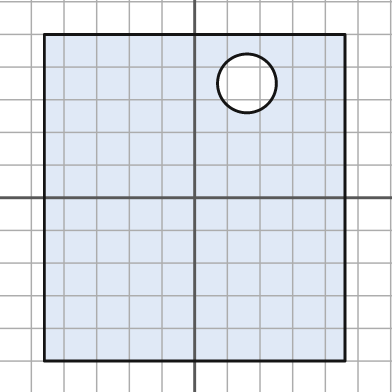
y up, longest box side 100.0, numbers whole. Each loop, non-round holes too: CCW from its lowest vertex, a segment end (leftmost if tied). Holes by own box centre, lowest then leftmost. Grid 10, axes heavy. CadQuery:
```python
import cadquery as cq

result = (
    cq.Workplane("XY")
    .moveTo(-46.0, -50.0)
    .lineTo(46.0, -50.0)
    .lineTo(46.0, 50.0)
    .lineTo(-46.0, 50.0)
    .close()
    .moveTo(16.0, 35.0)
    .circle(9.0)
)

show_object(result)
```